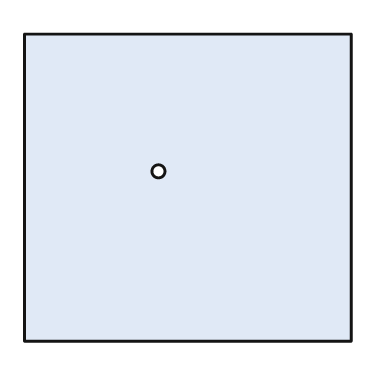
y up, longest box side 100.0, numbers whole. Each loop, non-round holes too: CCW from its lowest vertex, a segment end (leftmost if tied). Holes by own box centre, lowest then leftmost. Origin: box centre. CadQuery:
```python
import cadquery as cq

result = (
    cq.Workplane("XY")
    .moveTo(-50.0, -47.0)
    .lineTo(50.0, -47.0)
    .lineTo(50.0, 47.0)
    .lineTo(-50.0, 47.0)
    .close()
    .moveTo(-9.0, 5.0)
    .circle(2.0)
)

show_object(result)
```